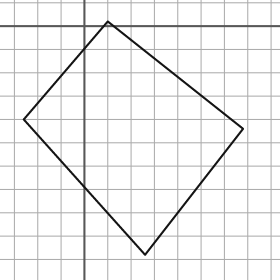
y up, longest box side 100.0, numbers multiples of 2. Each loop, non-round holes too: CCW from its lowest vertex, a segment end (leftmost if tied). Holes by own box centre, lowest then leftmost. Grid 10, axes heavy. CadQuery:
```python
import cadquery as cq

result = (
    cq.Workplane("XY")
    .moveTo(26.0, -98.0)
    .lineTo(68.0, -44.0)
    .lineTo(10.0, 2.0)
    .lineTo(-26.0, -40.0)
    .close()
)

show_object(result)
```